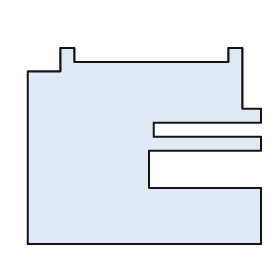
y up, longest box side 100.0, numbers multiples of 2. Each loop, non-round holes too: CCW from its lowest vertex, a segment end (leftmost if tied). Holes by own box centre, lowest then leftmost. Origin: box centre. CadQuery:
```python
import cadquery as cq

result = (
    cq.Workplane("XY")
    .moveTo(-50.0, -42.0)
    .lineTo(50.0, -42.0)
    .lineTo(50.0, -18.0)
    .lineTo(2.0, -18.0)
    .lineTo(2.0, -2.0)
    .lineTo(50.0, -2.0)
    .lineTo(50.0, 4.0)
    .lineTo(4.0, 4.0)
    .lineTo(4.0, 10.0)
    .lineTo(50.0, 10.0)
    .lineTo(50.0, 16.0)
    .lineTo(42.0, 16.0)
    .lineTo(42.0, 42.0)
    .lineTo(36.0, 42.0)
    .lineTo(36.0, 36.0)
    .lineTo(-30.0, 36.0)
    .lineTo(-30.0, 42.0)
    .lineTo(-36.0, 42.0)
    .lineTo(-36.0, 32.0)
    .lineTo(-50.0, 32.0)
    .close()
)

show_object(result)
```